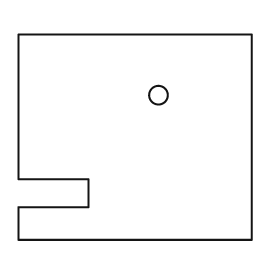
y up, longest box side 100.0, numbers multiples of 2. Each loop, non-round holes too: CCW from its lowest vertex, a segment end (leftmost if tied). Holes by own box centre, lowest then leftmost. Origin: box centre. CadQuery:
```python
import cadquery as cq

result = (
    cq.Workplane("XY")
    .moveTo(-50.0, -44.0)
    .lineTo(50.0, -44.0)
    .lineTo(50.0, 44.0)
    .lineTo(-50.0, 44.0)
    .lineTo(-50.0, -18.0)
    .lineTo(-20.0, -18.0)
    .lineTo(-20.0, -30.0)
    .lineTo(-50.0, -30.0)
    .close()
    .moveTo(10.0, 18.0)
    .circle(4.0)
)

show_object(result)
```